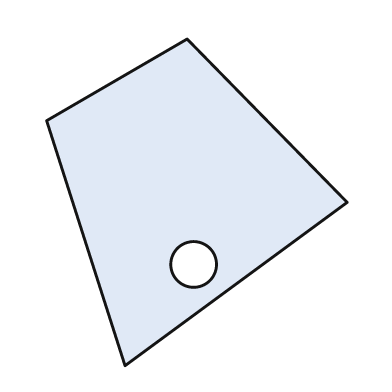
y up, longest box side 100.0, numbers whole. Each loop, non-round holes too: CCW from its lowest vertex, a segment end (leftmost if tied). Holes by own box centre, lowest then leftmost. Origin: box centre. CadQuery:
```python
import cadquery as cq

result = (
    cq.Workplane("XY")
    .moveTo(-22.0, -50.0)
    .lineTo(46.0, 0.0)
    .lineTo(-3.0, 50.0)
    .lineTo(-46.0, 25.0)
    .close()
    .moveTo(-1.0, -19.0)
    .circle(7.0)
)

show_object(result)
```